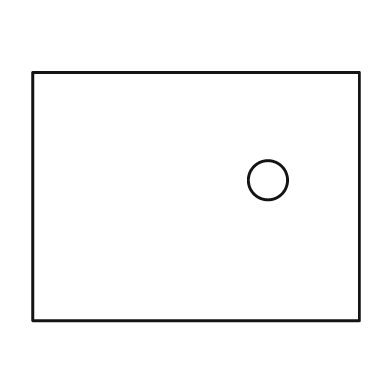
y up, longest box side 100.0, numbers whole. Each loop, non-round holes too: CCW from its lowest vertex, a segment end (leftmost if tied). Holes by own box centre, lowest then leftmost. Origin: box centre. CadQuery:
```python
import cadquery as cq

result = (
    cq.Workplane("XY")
    .moveTo(-50.0, -38.0)
    .lineTo(50.0, -38.0)
    .lineTo(50.0, 38.0)
    .lineTo(-50.0, 38.0)
    .close()
    .moveTo(22.0, 5.0)
    .circle(6.0)
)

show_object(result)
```